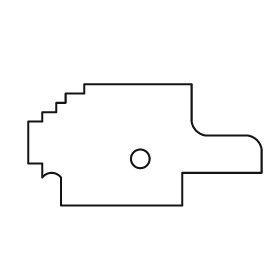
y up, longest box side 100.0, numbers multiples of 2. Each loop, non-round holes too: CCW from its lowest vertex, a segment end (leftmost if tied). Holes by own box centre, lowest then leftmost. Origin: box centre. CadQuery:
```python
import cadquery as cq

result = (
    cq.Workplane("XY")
    .moveTo(-36.0, -26.0)
    .lineTo(16.0, -26.0)
    .lineTo(16.0, -12.0)
    .lineTo(50.0, -12.0)
    .lineTo(50.0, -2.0)
    .threePointArc((48.0, 2.0), (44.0, 4.0))
    .lineTo(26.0, 4.0)
    .threePointArc((22.0, 6.0), (20.0, 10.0))
    .lineTo(20.0, 26.0)
    .lineTo(-26.0, 26.0)
    .lineTo(-26.0, 22.0)
    .lineTo(-34.0, 22.0)
    .lineTo(-34.0, 18.0)
    .lineTo(-38.0, 18.0)
    .lineTo(-38.0, 14.0)
    .lineTo(-44.0, 14.0)
    .lineTo(-44.0, 10.0)
    .lineTo(-50.0, 10.0)
    .lineTo(-50.0, -8.0)
    .lineTo(-44.0, -8.0)
    .lineTo(-44.0, -14.0)
    .threePointArc((-40.0, -12.0), (-36.0, -14.0))
    .close()
    .moveTo(-2.0, -6.0)
    .circle(4.0)
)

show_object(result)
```